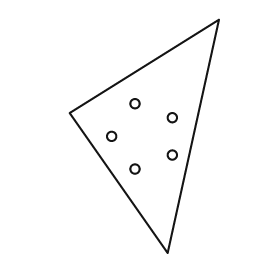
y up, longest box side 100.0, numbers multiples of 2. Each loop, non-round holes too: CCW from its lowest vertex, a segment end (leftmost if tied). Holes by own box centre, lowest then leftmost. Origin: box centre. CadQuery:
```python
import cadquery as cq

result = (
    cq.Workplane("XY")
    .moveTo(10.0, -50.0)
    .lineTo(32.0, 50.0)
    .lineTo(-32.0, 10.0)
    .close()
    .moveTo(-4.0, -14.0)
    .circle(2.0)
    .moveTo(12.0, -8.0)
    .circle(2.0)
    .moveTo(-14.0, 0.0)
    .circle(2.0)
    .moveTo(12.0, 8.0)
    .circle(2.0)
    .moveTo(-4.0, 14.0)
    .circle(2.0)
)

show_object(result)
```